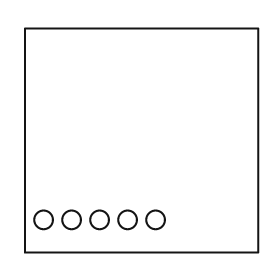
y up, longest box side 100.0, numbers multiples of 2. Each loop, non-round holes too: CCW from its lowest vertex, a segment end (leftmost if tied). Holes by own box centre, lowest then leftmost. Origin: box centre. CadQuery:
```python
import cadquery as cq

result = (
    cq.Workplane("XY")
    .moveTo(-50.0, -48.0)
    .lineTo(50.0, -48.0)
    .lineTo(50.0, 48.0)
    .lineTo(-50.0, 48.0)
    .close()
    .moveTo(-42.0, -34.0)
    .circle(4.0)
    .moveTo(-30.0, -34.0)
    .circle(4.0)
    .moveTo(-18.0, -34.0)
    .circle(4.0)
    .moveTo(-6.0, -34.0)
    .circle(4.0)
    .moveTo(6.0, -34.0)
    .circle(4.0)
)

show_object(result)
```